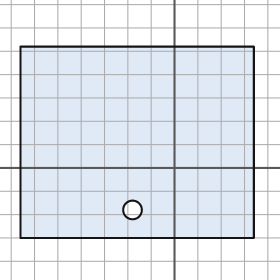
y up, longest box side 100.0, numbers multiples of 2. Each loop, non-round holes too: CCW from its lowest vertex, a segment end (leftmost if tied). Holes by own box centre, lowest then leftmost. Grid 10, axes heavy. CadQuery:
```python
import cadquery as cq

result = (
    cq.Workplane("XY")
    .moveTo(-66.0, -30.0)
    .lineTo(34.0, -30.0)
    .lineTo(34.0, 52.0)
    .lineTo(-66.0, 52.0)
    .close()
    .moveTo(-18.0, -18.0)
    .circle(4.0)
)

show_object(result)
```